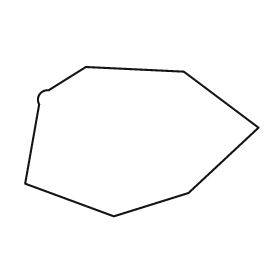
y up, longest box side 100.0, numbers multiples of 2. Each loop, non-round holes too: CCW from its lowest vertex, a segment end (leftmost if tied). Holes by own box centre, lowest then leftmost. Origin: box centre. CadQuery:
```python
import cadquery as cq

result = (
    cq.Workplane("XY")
    .moveTo(-12.0, -32.0)
    .lineTo(20.0, -22.0)
    .lineTo(50.0, 6.0)
    .lineTo(18.0, 30.0)
    .lineTo(-24.0, 32.0)
    .lineTo(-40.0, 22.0)
    .threePointArc((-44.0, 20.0), (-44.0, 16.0))
    .lineTo(-50.0, -18.0)
    .close()
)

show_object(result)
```